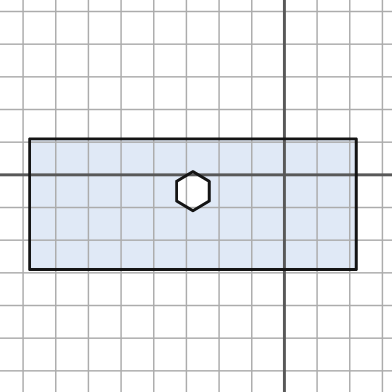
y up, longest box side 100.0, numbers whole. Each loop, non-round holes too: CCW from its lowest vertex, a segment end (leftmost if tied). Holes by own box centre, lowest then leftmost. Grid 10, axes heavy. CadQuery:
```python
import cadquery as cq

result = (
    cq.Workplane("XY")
    .moveTo(-78.0, -29.0)
    .lineTo(22.0, -29.0)
    .lineTo(22.0, 11.0)
    .lineTo(-78.0, 11.0)
    .close()
    .moveTo(-28.0, -11.0)
    .lineTo(-23.0, -8.0)
    .lineTo(-23.0, -2.0)
    .lineTo(-28.0, 1.0)
    .lineTo(-33.0, -2.0)
    .lineTo(-33.0, -8.0)
    .close()
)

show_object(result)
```